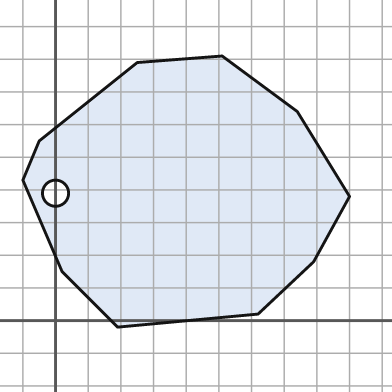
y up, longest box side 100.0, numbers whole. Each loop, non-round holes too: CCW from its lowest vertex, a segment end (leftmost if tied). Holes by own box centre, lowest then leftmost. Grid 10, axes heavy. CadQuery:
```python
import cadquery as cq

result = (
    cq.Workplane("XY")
    .moveTo(19.0, -2.0)
    .lineTo(62.0, 2.0)
    .lineTo(79.0, 18.0)
    .lineTo(90.0, 38.0)
    .lineTo(74.0, 64.0)
    .lineTo(51.0, 81.0)
    .lineTo(25.0, 79.0)
    .lineTo(-5.0, 55.0)
    .lineTo(-10.0, 43.0)
    .lineTo(2.0, 15.0)
    .close()
    .moveTo(0.0, 39.0)
    .circle(4.0)
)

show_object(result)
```